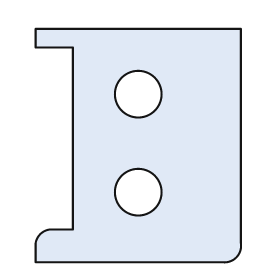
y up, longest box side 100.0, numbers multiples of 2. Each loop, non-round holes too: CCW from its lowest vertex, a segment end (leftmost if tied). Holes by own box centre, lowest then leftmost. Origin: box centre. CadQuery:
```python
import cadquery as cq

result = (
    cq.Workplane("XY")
    .moveTo(-44.0, -50.0)
    .lineTo(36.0, -50.0)
    .threePointArc((42.0, -48.0), (44.0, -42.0))
    .lineTo(44.0, 50.0)
    .lineTo(-44.0, 50.0)
    .lineTo(-44.0, 42.0)
    .lineTo(-28.0, 42.0)
    .lineTo(-28.0, -36.0)
    .lineTo(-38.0, -36.0)
    .threePointArc((-42.0, -38.0), (-44.0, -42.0))
    .close()
    .moveTo(0.0, -20.0)
    .circle(10.0)
    .moveTo(0.0, 22.0)
    .circle(10.0)
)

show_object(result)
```